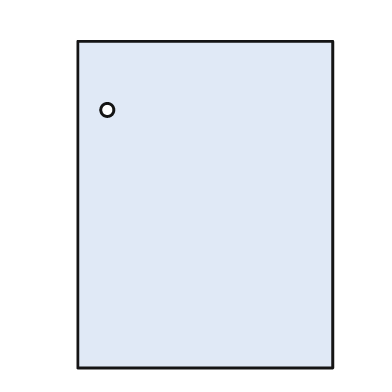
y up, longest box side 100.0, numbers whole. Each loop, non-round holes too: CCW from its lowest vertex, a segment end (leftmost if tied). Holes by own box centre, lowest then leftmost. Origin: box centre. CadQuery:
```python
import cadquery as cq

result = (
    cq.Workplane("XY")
    .moveTo(-39.0, -50.0)
    .lineTo(39.0, -50.0)
    .lineTo(39.0, 50.0)
    .lineTo(-39.0, 50.0)
    .close()
    .moveTo(-30.0, 29.0)
    .circle(2.0)
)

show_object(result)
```